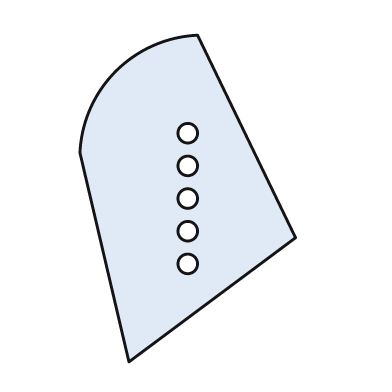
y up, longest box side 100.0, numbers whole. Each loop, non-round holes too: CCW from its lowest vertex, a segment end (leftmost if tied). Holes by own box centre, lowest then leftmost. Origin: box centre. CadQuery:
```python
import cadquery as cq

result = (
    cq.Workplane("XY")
    .moveTo(-18.0, -50.0)
    .lineTo(33.0, -12.0)
    .lineTo(3.0, 50.0)
    .threePointArc((-22.0, 39.0), (-33.0, 14.0))
    .close()
    .moveTo(0.0, -20.0)
    .circle(3.0)
    .moveTo(0.0, -10.0)
    .circle(3.0)
    .moveTo(0.0, 0.0)
    .circle(3.0)
    .moveTo(0.0, 10.0)
    .circle(3.0)
    .moveTo(0.0, 20.0)
    .circle(3.0)
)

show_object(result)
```